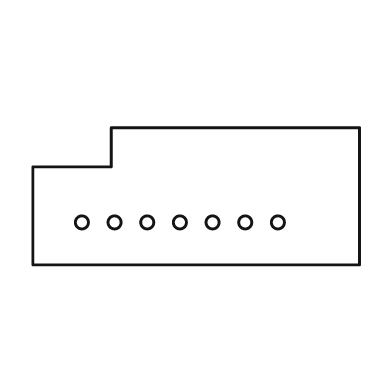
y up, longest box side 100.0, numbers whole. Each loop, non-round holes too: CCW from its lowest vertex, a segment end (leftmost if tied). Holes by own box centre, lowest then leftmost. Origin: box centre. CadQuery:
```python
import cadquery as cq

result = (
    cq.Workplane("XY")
    .moveTo(-50.0, -21.0)
    .lineTo(50.0, -21.0)
    .lineTo(50.0, 21.0)
    .lineTo(-26.0, 21.0)
    .lineTo(-26.0, 9.0)
    .lineTo(-50.0, 9.0)
    .close()
    .moveTo(-35.0, -8.0)
    .circle(2.0)
    .moveTo(-25.0, -8.0)
    .circle(2.0)
    .moveTo(-15.0, -8.0)
    .circle(2.0)
    .moveTo(-5.0, -8.0)
    .circle(2.0)
    .moveTo(5.0, -8.0)
    .circle(2.0)
    .moveTo(15.0, -8.0)
    .circle(2.0)
    .moveTo(25.0, -8.0)
    .circle(2.0)
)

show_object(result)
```